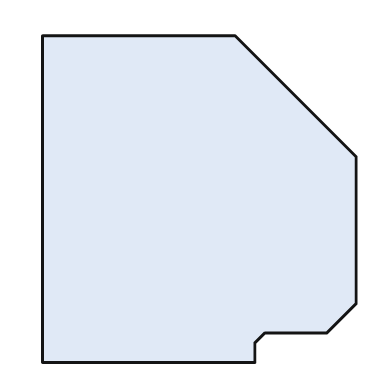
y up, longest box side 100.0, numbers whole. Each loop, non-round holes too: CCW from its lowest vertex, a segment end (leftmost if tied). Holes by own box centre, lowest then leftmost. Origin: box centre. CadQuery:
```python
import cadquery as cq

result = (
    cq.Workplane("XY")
    .moveTo(-48.0, -50.0)
    .lineTo(17.0, -50.0)
    .lineTo(17.0, -44.0)
    .lineTo(20.0, -41.0)
    .lineTo(39.0, -41.0)
    .lineTo(48.0, -32.0)
    .lineTo(48.0, 13.0)
    .lineTo(11.0, 50.0)
    .lineTo(-48.0, 50.0)
    .close()
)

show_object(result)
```